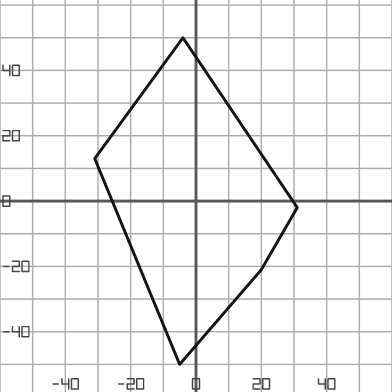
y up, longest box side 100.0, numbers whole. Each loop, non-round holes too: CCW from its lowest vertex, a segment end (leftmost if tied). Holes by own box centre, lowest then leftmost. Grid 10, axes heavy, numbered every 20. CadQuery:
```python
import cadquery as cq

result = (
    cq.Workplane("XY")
    .moveTo(-5.0, -50.0)
    .lineTo(20.0, -21.0)
    .lineTo(31.0, -2.0)
    .lineTo(-4.0, 50.0)
    .lineTo(-31.0, 13.0)
    .close()
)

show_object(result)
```